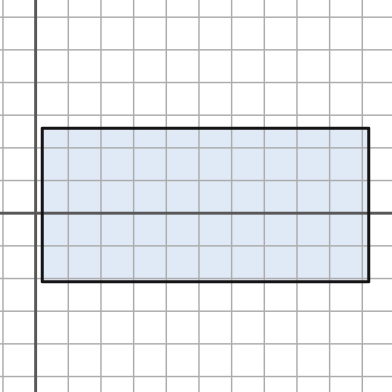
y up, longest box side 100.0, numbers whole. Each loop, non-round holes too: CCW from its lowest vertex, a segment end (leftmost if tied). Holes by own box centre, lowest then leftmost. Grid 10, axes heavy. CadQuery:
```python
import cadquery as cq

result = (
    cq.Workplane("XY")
    .moveTo(2.0, -21.0)
    .lineTo(102.0, -21.0)
    .lineTo(102.0, 26.0)
    .lineTo(2.0, 26.0)
    .close()
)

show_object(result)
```